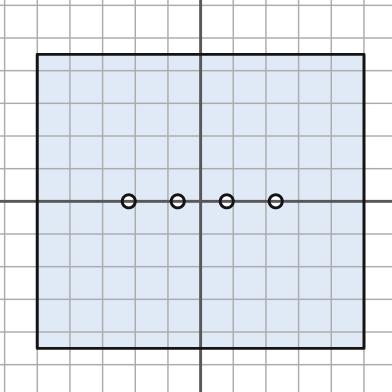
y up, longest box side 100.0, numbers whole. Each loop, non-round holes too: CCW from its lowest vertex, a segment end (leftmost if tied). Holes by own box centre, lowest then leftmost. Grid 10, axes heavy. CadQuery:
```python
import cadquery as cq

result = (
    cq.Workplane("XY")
    .moveTo(-50.0, -45.0)
    .lineTo(50.0, -45.0)
    .lineTo(50.0, 45.0)
    .lineTo(-50.0, 45.0)
    .close()
    .moveTo(-22.0, 0.0)
    .circle(2.0)
    .moveTo(-7.0, 0.0)
    .circle(2.0)
    .moveTo(8.0, 0.0)
    .circle(2.0)
    .moveTo(23.0, 0.0)
    .circle(2.0)
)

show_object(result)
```